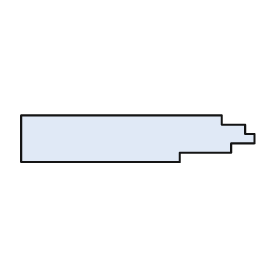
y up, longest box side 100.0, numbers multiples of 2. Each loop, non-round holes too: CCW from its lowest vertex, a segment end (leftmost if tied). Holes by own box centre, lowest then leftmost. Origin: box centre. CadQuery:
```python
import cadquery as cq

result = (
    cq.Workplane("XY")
    .moveTo(-50.0, -10.0)
    .lineTo(18.0, -10.0)
    .lineTo(18.0, -6.0)
    .lineTo(40.0, -6.0)
    .lineTo(40.0, -2.0)
    .lineTo(50.0, -2.0)
    .lineTo(50.0, 2.0)
    .lineTo(46.0, 2.0)
    .lineTo(46.0, 6.0)
    .lineTo(36.0, 6.0)
    .lineTo(36.0, 10.0)
    .lineTo(-50.0, 10.0)
    .close()
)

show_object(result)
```